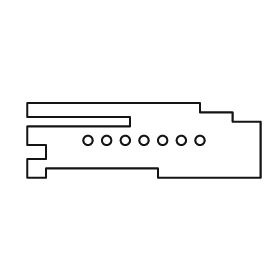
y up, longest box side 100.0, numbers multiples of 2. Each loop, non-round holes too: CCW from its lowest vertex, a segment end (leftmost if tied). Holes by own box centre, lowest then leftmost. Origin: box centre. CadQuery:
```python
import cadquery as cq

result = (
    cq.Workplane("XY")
    .moveTo(-50.0, -16.0)
    .lineTo(-42.0, -16.0)
    .lineTo(-42.0, -12.0)
    .lineTo(6.0, -12.0)
    .lineTo(6.0, -16.0)
    .lineTo(50.0, -16.0)
    .lineTo(50.0, 8.0)
    .lineTo(38.0, 8.0)
    .lineTo(38.0, 12.0)
    .lineTo(24.0, 12.0)
    .lineTo(24.0, 16.0)
    .lineTo(-50.0, 16.0)
    .lineTo(-50.0, 10.0)
    .lineTo(-6.0, 10.0)
    .lineTo(-6.0, 6.0)
    .lineTo(-50.0, 6.0)
    .lineTo(-50.0, -2.0)
    .lineTo(-42.0, -2.0)
    .lineTo(-42.0, -8.0)
    .lineTo(-50.0, -8.0)
    .close()
    .moveTo(-24.0, 0.0)
    .circle(2.0)
    .moveTo(-16.0, 0.0)
    .circle(2.0)
    .moveTo(-8.0, 0.0)
    .circle(2.0)
    .moveTo(0.0, 0.0)
    .circle(2.0)
    .moveTo(8.0, 0.0)
    .circle(2.0)
    .moveTo(16.0, 0.0)
    .circle(2.0)
    .moveTo(24.0, 0.0)
    .circle(2.0)
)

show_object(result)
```